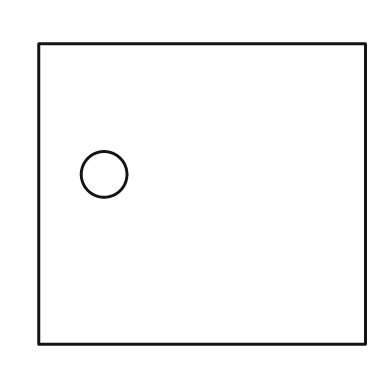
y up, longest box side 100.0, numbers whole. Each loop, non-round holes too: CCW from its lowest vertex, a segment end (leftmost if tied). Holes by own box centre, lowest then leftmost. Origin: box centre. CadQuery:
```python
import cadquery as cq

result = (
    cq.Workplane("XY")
    .moveTo(-50.0, -46.0)
    .lineTo(50.0, -46.0)
    .lineTo(50.0, 46.0)
    .lineTo(-50.0, 46.0)
    .close()
    .moveTo(-30.0, 6.0)
    .circle(7.0)
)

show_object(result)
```